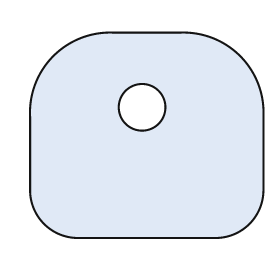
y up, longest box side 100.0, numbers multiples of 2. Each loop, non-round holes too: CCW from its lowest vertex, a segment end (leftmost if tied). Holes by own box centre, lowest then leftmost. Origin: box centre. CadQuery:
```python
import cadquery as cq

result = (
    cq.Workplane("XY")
    .moveTo(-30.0, -44.0)
    .lineTo(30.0, -44.0)
    .threePointArc((44.0, -38.0), (50.0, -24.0))
    .lineTo(50.0, 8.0)
    .threePointArc((40.0, 34.0), (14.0, 44.0))
    .lineTo(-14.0, 44.0)
    .threePointArc((-40.0, 34.0), (-50.0, 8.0))
    .lineTo(-50.0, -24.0)
    .threePointArc((-44.0, -38.0), (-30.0, -44.0))
    .close()
    .moveTo(-2.0, 12.0)
    .circle(10.0)
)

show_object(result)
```